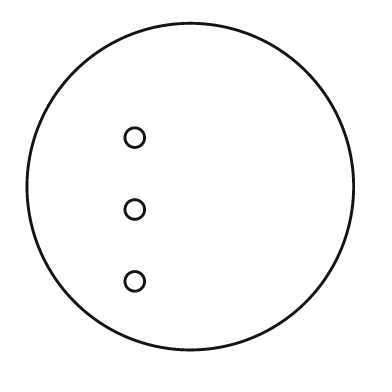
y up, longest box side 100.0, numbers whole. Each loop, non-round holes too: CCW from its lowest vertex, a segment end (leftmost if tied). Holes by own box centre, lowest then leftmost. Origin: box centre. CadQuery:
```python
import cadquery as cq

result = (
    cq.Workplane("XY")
    .moveTo(0.0, 0.0)
    .circle(50.0)
    .moveTo(-17.0, -29.0)
    .circle(3.0)
    .moveTo(-17.0, -7.0)
    .circle(3.0)
    .moveTo(-17.0, 15.0)
    .circle(3.0)
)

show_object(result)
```